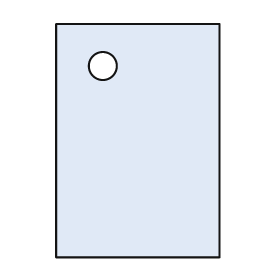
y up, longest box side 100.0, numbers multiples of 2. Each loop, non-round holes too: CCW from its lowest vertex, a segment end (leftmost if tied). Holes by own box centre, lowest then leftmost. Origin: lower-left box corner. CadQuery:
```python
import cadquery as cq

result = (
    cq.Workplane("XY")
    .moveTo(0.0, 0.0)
    .lineTo(70.0, 0.0)
    .lineTo(70.0, 100.0)
    .lineTo(0.0, 100.0)
    .close()
    .moveTo(20.0, 82.0)
    .circle(6.0)
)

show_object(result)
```